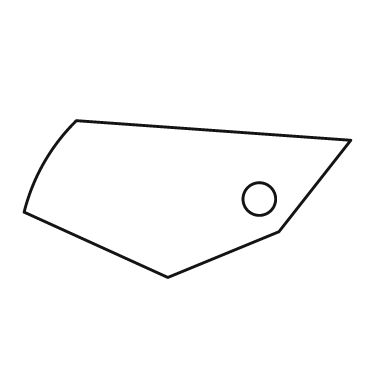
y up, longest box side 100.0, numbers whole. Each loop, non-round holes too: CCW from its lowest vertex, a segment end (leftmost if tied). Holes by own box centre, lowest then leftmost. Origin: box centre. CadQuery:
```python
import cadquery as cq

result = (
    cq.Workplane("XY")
    .moveTo(-6.0, -24.0)
    .lineTo(28.0, -10.0)
    .lineTo(50.0, 18.0)
    .lineTo(-34.0, 24.0)
    .threePointArc((-44.0, 11.0), (-50.0, -4.0))
    .close()
    .moveTo(22.0, 0.0)
    .circle(5.0)
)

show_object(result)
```